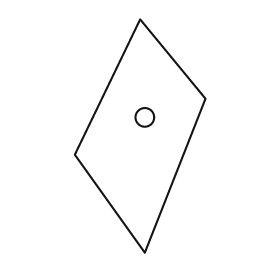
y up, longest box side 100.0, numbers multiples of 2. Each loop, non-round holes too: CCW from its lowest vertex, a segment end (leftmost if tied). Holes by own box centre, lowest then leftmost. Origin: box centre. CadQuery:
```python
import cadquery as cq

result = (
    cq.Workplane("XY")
    .moveTo(2.0, -50.0)
    .lineTo(28.0, 16.0)
    .lineTo(0.0, 50.0)
    .lineTo(-28.0, -8.0)
    .close()
    .moveTo(2.0, 8.0)
    .circle(4.0)
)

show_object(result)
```